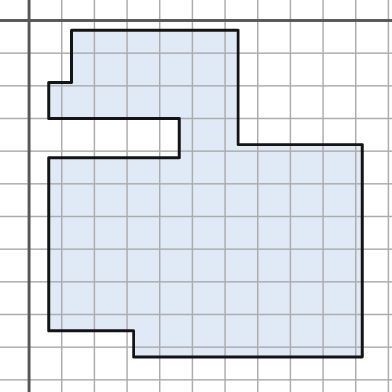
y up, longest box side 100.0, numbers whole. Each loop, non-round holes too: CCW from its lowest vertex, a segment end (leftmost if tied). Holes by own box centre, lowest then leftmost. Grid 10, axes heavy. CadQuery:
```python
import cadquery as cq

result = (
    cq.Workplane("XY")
    .moveTo(32.0, -103.0)
    .lineTo(102.0, -103.0)
    .lineTo(102.0, -38.0)
    .lineTo(64.0, -38.0)
    .lineTo(64.0, -3.0)
    .lineTo(13.0, -3.0)
    .lineTo(13.0, -19.0)
    .lineTo(6.0, -19.0)
    .lineTo(6.0, -30.0)
    .lineTo(46.0, -30.0)
    .lineTo(46.0, -42.0)
    .lineTo(6.0, -42.0)
    .lineTo(6.0, -95.0)
    .lineTo(32.0, -95.0)
    .close()
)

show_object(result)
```